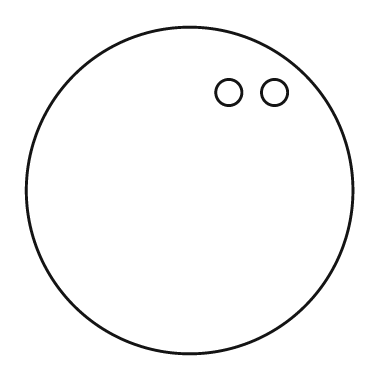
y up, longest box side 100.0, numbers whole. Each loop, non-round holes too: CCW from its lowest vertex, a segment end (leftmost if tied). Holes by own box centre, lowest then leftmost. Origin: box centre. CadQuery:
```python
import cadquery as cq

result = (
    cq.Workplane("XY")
    .moveTo(0.0, 0.0)
    .circle(50.0)
    .moveTo(12.0, 30.0)
    .circle(4.0)
    .moveTo(26.0, 30.0)
    .circle(4.0)
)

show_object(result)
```